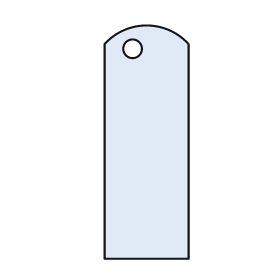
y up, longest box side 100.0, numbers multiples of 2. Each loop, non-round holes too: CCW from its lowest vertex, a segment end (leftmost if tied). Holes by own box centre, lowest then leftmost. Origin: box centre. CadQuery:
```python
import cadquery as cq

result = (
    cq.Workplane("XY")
    .moveTo(-18.0, -50.0)
    .lineTo(18.0, -50.0)
    .lineTo(18.0, 42.0)
    .threePointArc((0.0, 50.0), (-18.0, 42.0))
    .close()
    .moveTo(-6.0, 40.0)
    .circle(4.0)
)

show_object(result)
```